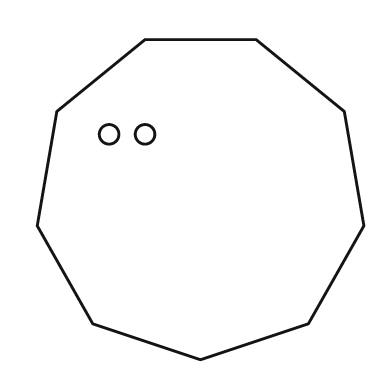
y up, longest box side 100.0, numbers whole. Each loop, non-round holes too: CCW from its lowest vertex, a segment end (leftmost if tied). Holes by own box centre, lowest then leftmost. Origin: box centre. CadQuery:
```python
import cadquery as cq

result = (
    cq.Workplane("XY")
    .moveTo(0.0, -49.0)
    .lineTo(33.0, -38.0)
    .lineTo(50.0, -8.0)
    .lineTo(44.0, 27.0)
    .lineTo(17.0, 49.0)
    .lineTo(-17.0, 49.0)
    .lineTo(-44.0, 27.0)
    .lineTo(-50.0, -8.0)
    .lineTo(-33.0, -38.0)
    .close()
    .moveTo(-28.0, 20.0)
    .circle(3.0)
    .moveTo(-17.0, 20.0)
    .circle(3.0)
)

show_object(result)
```